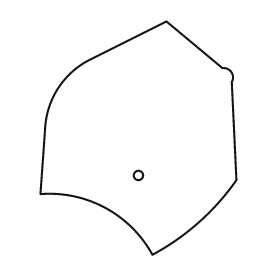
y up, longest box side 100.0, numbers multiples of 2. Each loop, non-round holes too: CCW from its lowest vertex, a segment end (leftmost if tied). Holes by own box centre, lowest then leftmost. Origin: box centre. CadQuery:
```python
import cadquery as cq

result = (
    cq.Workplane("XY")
    .moveTo(6.0, -50.0)
    .threePointArc((26.0, -36.0), (42.0, -18.0))
    .lineTo(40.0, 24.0)
    .threePointArc((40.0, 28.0), (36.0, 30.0))
    .lineTo(12.0, 50.0)
    .lineTo(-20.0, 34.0)
    .threePointArc((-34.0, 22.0), (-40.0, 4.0))
    .lineTo(-42.0, -24.0)
    .threePointArc((-14.0, -30.0), (6.0, -50.0))
    .close()
    .moveTo(0.0, -16.0)
    .circle(2.0)
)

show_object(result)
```